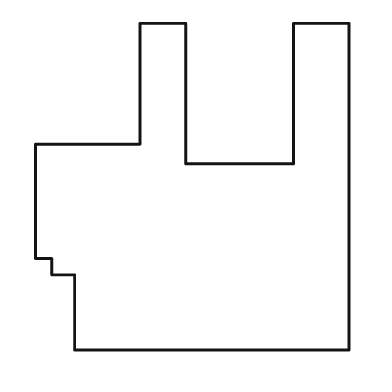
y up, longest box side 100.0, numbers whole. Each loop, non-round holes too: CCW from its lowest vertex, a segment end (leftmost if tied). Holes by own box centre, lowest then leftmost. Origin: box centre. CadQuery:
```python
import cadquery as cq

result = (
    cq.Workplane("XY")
    .moveTo(-36.0, -50.0)
    .lineTo(48.0, -50.0)
    .lineTo(48.0, 50.0)
    .lineTo(31.0, 50.0)
    .lineTo(31.0, 7.0)
    .lineTo(-2.0, 7.0)
    .lineTo(-2.0, 50.0)
    .lineTo(-16.0, 50.0)
    .lineTo(-16.0, 13.0)
    .lineTo(-48.0, 13.0)
    .lineTo(-48.0, -22.0)
    .lineTo(-43.0, -22.0)
    .lineTo(-43.0, -27.0)
    .lineTo(-36.0, -27.0)
    .close()
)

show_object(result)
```